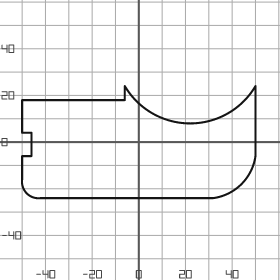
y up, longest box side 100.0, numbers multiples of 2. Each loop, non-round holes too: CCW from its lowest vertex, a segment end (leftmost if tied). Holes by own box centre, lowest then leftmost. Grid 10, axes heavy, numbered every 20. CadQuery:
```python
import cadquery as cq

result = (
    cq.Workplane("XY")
    .moveTo(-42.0, -24.0)
    .lineTo(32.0, -24.0)
    .threePointArc((44.0, -18.0), (50.0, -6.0))
    .lineTo(50.0, 24.0)
    .threePointArc((22.0, 8.0), (-6.0, 24.0))
    .lineTo(-6.0, 18.0)
    .lineTo(-50.0, 18.0)
    .lineTo(-50.0, 4.0)
    .lineTo(-46.0, 4.0)
    .lineTo(-46.0, -6.0)
    .lineTo(-50.0, -6.0)
    .lineTo(-50.0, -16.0)
    .threePointArc((-48.0, -22.0), (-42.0, -24.0))
    .close()
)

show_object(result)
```